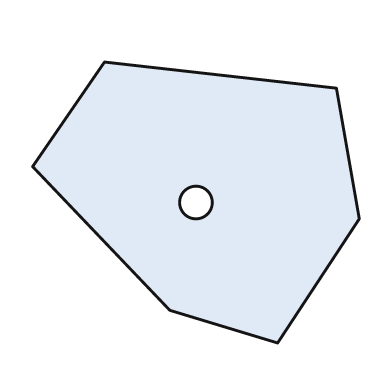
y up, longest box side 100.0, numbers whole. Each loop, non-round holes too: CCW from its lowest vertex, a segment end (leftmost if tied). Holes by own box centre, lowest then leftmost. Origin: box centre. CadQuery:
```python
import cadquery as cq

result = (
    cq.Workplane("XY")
    .moveTo(25.0, -43.0)
    .lineTo(50.0, -5.0)
    .lineTo(43.0, 35.0)
    .lineTo(-28.0, 43.0)
    .lineTo(-50.0, 11.0)
    .lineTo(-8.0, -33.0)
    .close()
    .moveTo(0.0, 0.0)
    .circle(5.0)
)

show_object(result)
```